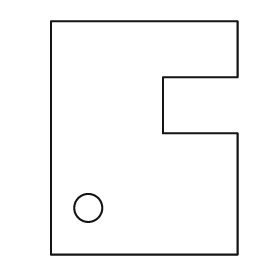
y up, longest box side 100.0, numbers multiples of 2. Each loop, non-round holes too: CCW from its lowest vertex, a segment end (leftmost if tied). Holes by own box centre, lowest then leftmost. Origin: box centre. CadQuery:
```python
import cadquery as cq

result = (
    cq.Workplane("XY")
    .moveTo(-40.0, -50.0)
    .lineTo(40.0, -50.0)
    .lineTo(40.0, 2.0)
    .lineTo(8.0, 2.0)
    .lineTo(8.0, 26.0)
    .lineTo(40.0, 26.0)
    .lineTo(40.0, 50.0)
    .lineTo(-40.0, 50.0)
    .close()
    .moveTo(-24.0, -30.0)
    .circle(6.0)
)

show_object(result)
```